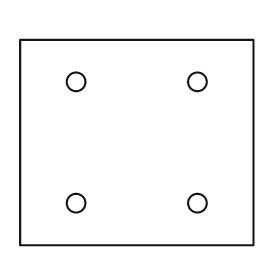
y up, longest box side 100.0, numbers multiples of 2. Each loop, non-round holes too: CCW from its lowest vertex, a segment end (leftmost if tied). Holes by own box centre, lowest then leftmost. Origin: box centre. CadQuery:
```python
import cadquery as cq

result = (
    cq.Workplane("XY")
    .moveTo(-50.0, -44.0)
    .lineTo(50.0, -44.0)
    .lineTo(50.0, 44.0)
    .lineTo(-50.0, 44.0)
    .close()
    .moveTo(-26.0, -26.0)
    .circle(4.0)
    .moveTo(26.0, -26.0)
    .circle(4.0)
    .moveTo(-26.0, 26.0)
    .circle(4.0)
    .moveTo(26.0, 26.0)
    .circle(4.0)
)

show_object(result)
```